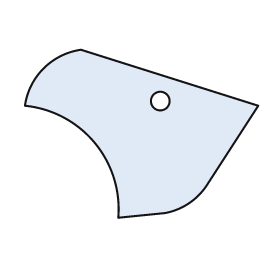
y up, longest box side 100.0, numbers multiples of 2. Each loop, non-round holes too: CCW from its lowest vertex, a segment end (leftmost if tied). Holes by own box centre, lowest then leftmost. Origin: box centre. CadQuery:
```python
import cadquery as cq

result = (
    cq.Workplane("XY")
    .moveTo(-10.0, -36.0)
    .lineTo(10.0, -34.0)
    .threePointArc((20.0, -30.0), (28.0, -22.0))
    .lineTo(50.0, 12.0)
    .lineTo(-26.0, 36.0)
    .threePointArc((-42.0, 28.0), (-50.0, 12.0))
    .threePointArc((-20.0, -4.0), (-10.0, -36.0))
    .close()
    .moveTo(8.0, 14.0)
    .circle(4.0)
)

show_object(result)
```